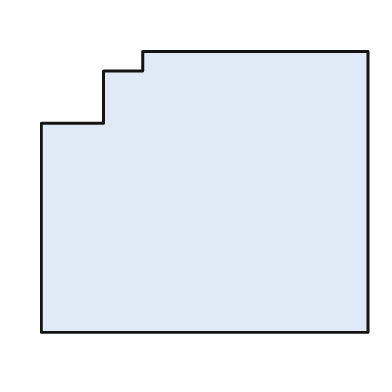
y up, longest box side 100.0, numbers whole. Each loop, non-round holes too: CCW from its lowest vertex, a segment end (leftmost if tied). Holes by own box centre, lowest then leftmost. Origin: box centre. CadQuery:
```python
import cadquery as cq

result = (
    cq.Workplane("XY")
    .moveTo(-50.0, -43.0)
    .lineTo(50.0, -43.0)
    .lineTo(50.0, 43.0)
    .lineTo(-19.0, 43.0)
    .lineTo(-19.0, 37.0)
    .lineTo(-31.0, 37.0)
    .lineTo(-31.0, 21.0)
    .lineTo(-50.0, 21.0)
    .close()
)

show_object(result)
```